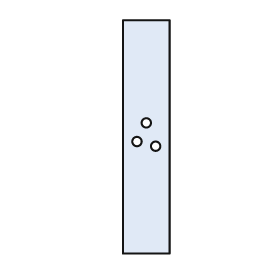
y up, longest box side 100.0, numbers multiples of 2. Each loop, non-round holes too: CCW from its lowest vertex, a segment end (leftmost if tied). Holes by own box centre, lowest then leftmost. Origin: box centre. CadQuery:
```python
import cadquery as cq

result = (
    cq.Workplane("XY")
    .moveTo(-10.0, -50.0)
    .lineTo(10.0, -50.0)
    .lineTo(10.0, 50.0)
    .lineTo(-10.0, 50.0)
    .close()
    .moveTo(4.0, -4.0)
    .circle(2.0)
    .moveTo(-4.0, -2.0)
    .circle(2.0)
    .moveTo(0.0, 6.0)
    .circle(2.0)
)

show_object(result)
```